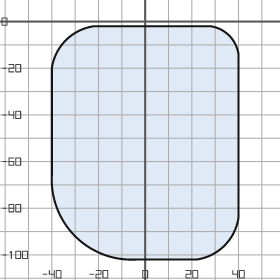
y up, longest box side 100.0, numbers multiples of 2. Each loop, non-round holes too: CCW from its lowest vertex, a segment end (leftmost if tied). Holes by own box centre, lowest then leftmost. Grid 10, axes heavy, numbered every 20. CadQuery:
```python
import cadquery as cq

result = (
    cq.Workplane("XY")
    .moveTo(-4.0, -102.0)
    .lineTo(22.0, -102.0)
    .threePointArc((34.0, -96.0), (40.0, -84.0))
    .lineTo(40.0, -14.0)
    .threePointArc((36.0, -6.0), (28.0, -2.0))
    .lineTo(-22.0, -2.0)
    .threePointArc((-34.0, -8.0), (-40.0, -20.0))
    .lineTo(-40.0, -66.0)
    .threePointArc((-30.0, -92.0), (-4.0, -102.0))
    .close()
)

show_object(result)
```